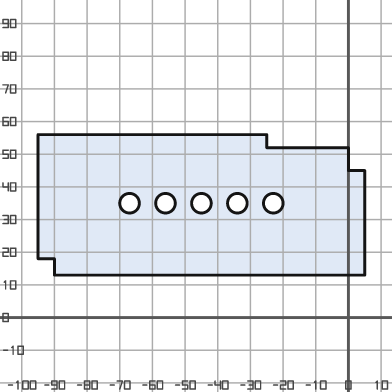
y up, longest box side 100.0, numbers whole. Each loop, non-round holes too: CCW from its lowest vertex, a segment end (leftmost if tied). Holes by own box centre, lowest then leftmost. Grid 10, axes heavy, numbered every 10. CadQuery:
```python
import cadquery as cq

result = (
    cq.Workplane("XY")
    .moveTo(-90.0, 13.0)
    .lineTo(5.0, 13.0)
    .lineTo(5.0, 45.0)
    .lineTo(0.0, 45.0)
    .lineTo(0.0, 52.0)
    .lineTo(-25.0, 52.0)
    .lineTo(-25.0, 56.0)
    .lineTo(-95.0, 56.0)
    .lineTo(-95.0, 18.0)
    .lineTo(-90.0, 18.0)
    .close()
    .moveTo(-67.0, 35.0)
    .circle(3.0)
    .moveTo(-56.0, 35.0)
    .circle(3.0)
    .moveTo(-45.0, 35.0)
    .circle(3.0)
    .moveTo(-34.0, 35.0)
    .circle(3.0)
    .moveTo(-23.0, 35.0)
    .circle(3.0)
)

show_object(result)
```